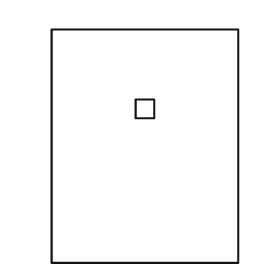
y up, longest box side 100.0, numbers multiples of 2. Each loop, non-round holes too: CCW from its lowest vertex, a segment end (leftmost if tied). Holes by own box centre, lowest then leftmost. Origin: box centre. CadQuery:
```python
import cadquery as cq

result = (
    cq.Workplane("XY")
    .moveTo(-40.0, -50.0)
    .lineTo(40.0, -50.0)
    .lineTo(40.0, 50.0)
    .lineTo(-40.0, 50.0)
    .close()
    .moveTo(-4.0, 12.0)
    .lineTo(4.0, 12.0)
    .lineTo(4.0, 20.0)
    .lineTo(-4.0, 20.0)
    .close()
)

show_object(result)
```